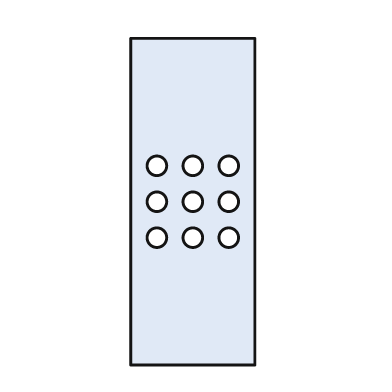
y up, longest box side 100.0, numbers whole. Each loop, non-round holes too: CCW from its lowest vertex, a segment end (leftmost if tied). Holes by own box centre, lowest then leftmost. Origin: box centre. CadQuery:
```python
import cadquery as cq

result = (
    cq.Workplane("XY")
    .moveTo(-19.0, -50.0)
    .lineTo(19.0, -50.0)
    .lineTo(19.0, 50.0)
    .lineTo(-19.0, 50.0)
    .close()
    .moveTo(-11.0, -11.0)
    .circle(3.0)
    .moveTo(0.0, -11.0)
    .circle(3.0)
    .moveTo(11.0, -11.0)
    .circle(3.0)
    .moveTo(-11.0, 0.0)
    .circle(3.0)
    .moveTo(0.0, 0.0)
    .circle(3.0)
    .moveTo(11.0, 0.0)
    .circle(3.0)
    .moveTo(-11.0, 11.0)
    .circle(3.0)
    .moveTo(0.0, 11.0)
    .circle(3.0)
    .moveTo(11.0, 11.0)
    .circle(3.0)
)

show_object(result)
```